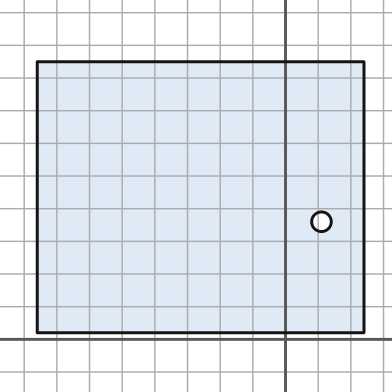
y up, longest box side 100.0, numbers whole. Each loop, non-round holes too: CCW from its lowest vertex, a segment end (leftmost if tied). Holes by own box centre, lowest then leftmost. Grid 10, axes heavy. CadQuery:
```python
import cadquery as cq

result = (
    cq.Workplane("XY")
    .moveTo(-76.0, 2.0)
    .lineTo(24.0, 2.0)
    .lineTo(24.0, 85.0)
    .lineTo(-76.0, 85.0)
    .close()
    .moveTo(11.0, 36.0)
    .circle(3.0)
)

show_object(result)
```